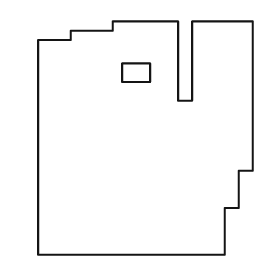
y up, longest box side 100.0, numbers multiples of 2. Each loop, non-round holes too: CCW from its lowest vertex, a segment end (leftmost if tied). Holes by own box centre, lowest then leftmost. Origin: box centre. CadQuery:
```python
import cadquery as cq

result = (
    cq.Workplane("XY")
    .moveTo(-46.0, -50.0)
    .lineTo(34.0, -50.0)
    .lineTo(34.0, -30.0)
    .lineTo(40.0, -30.0)
    .lineTo(40.0, -14.0)
    .lineTo(46.0, -14.0)
    .lineTo(46.0, 50.0)
    .lineTo(20.0, 50.0)
    .lineTo(20.0, 16.0)
    .lineTo(14.0, 16.0)
    .lineTo(14.0, 50.0)
    .lineTo(-14.0, 50.0)
    .lineTo(-14.0, 46.0)
    .lineTo(-32.0, 46.0)
    .lineTo(-32.0, 42.0)
    .lineTo(-46.0, 42.0)
    .close()
    .moveTo(-10.0, 24.0)
    .lineTo(2.0, 24.0)
    .lineTo(2.0, 32.0)
    .lineTo(-10.0, 32.0)
    .close()
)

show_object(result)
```